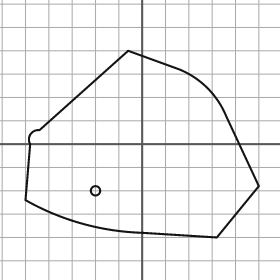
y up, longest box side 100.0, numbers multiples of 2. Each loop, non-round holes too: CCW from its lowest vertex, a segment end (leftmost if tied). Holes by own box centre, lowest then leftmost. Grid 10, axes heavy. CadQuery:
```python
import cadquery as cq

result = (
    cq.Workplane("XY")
    .moveTo(32.0, -40.0)
    .lineTo(50.0, -18.0)
    .lineTo(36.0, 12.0)
    .threePointArc((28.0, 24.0), (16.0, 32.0))
    .lineTo(-6.0, 40.0)
    .lineTo(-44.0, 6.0)
    .threePointArc((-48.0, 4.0), (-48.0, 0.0))
    .lineTo(-50.0, -24.0)
    .threePointArc((-26.0, -34.0), (0.0, -38.0))
    .close()
    .moveTo(-20.0, -20.0)
    .circle(2.0)
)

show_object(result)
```